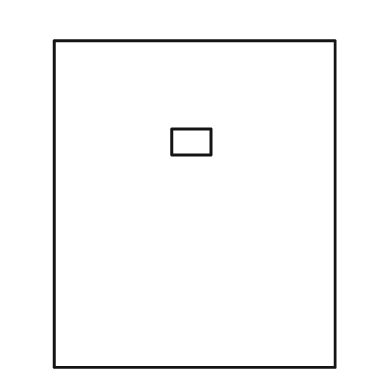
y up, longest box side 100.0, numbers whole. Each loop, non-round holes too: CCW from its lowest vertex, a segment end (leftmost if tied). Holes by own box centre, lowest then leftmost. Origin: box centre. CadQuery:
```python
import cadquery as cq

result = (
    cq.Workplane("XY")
    .moveTo(-43.0, -50.0)
    .lineTo(43.0, -50.0)
    .lineTo(43.0, 50.0)
    .lineTo(-43.0, 50.0)
    .close()
    .moveTo(-7.0, 15.0)
    .lineTo(5.0, 15.0)
    .lineTo(5.0, 23.0)
    .lineTo(-7.0, 23.0)
    .close()
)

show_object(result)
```